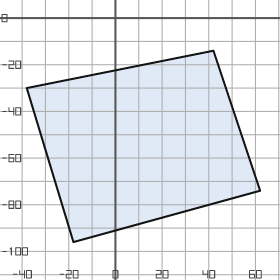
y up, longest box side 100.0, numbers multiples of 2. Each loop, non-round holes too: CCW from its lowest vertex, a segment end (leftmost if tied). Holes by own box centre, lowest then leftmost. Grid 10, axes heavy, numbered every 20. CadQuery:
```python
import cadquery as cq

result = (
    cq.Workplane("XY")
    .moveTo(-18.0, -96.0)
    .lineTo(62.0, -74.0)
    .lineTo(42.0, -14.0)
    .lineTo(-38.0, -30.0)
    .close()
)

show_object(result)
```